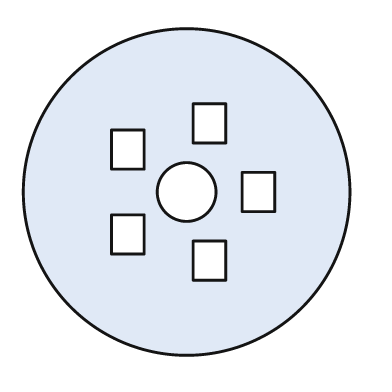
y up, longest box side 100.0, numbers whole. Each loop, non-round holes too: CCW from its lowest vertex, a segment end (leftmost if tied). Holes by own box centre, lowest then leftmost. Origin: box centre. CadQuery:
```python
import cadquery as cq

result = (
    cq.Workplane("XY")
    .moveTo(0.0, 0.0)
    .circle(50.0)
    .moveTo(2.0, -27.0)
    .lineTo(12.0, -27.0)
    .lineTo(12.0, -15.0)
    .lineTo(2.0, -15.0)
    .close()
    .moveTo(-23.0, -19.0)
    .lineTo(-13.0, -19.0)
    .lineTo(-13.0, -7.0)
    .lineTo(-23.0, -7.0)
    .close()
    .moveTo(0.0, 0.0)
    .circle(9.0)
    .moveTo(17.0, -6.0)
    .lineTo(27.0, -6.0)
    .lineTo(27.0, 6.0)
    .lineTo(17.0, 6.0)
    .close()
    .moveTo(-23.0, 7.0)
    .lineTo(-13.0, 7.0)
    .lineTo(-13.0, 19.0)
    .lineTo(-23.0, 19.0)
    .close()
    .moveTo(2.0, 15.0)
    .lineTo(12.0, 15.0)
    .lineTo(12.0, 27.0)
    .lineTo(2.0, 27.0)
    .close()
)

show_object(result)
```